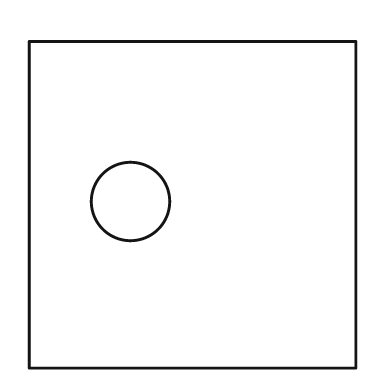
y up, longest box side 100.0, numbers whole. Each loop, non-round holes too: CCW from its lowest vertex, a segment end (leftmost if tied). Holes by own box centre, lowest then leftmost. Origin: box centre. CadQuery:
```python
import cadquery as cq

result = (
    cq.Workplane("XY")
    .moveTo(-50.0, -50.0)
    .lineTo(50.0, -50.0)
    .lineTo(50.0, 50.0)
    .lineTo(-50.0, 50.0)
    .close()
    .moveTo(-19.0, 1.0)
    .circle(12.0)
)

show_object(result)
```